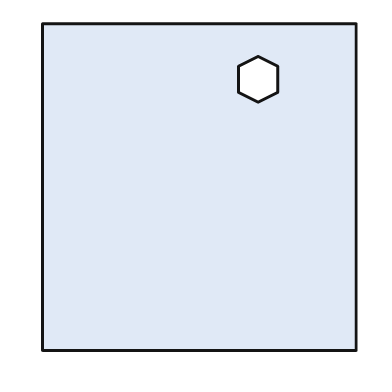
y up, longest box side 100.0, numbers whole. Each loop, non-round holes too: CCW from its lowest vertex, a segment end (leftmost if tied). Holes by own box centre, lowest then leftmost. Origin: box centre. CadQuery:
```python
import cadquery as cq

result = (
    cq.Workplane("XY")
    .moveTo(-48.0, -50.0)
    .lineTo(48.0, -50.0)
    .lineTo(48.0, 50.0)
    .lineTo(-48.0, 50.0)
    .close()
    .moveTo(18.0, 26.0)
    .lineTo(24.0, 29.0)
    .lineTo(24.0, 37.0)
    .lineTo(18.0, 40.0)
    .lineTo(12.0, 37.0)
    .lineTo(12.0, 29.0)
    .close()
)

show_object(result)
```